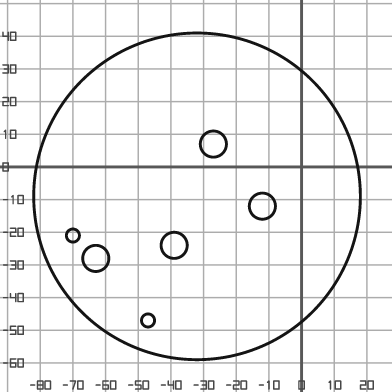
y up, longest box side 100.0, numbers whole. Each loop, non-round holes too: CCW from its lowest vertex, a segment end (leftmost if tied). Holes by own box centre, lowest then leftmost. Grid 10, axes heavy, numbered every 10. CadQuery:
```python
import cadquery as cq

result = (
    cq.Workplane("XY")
    .moveTo(-32.0, -9.0)
    .circle(50.0)
    .moveTo(-47.0, -47.0)
    .circle(2.0)
    .moveTo(-63.0, -28.0)
    .circle(4.0)
    .moveTo(-39.0, -24.0)
    .circle(4.0)
    .moveTo(-70.0, -21.0)
    .circle(2.0)
    .moveTo(-12.0, -12.0)
    .circle(4.0)
    .moveTo(-27.0, 7.0)
    .circle(4.0)
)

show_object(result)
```